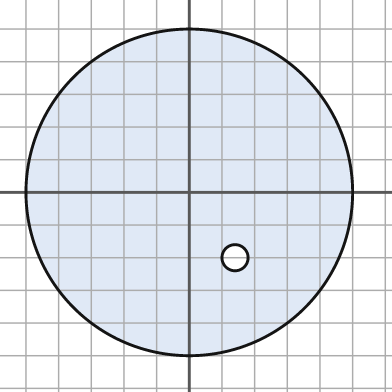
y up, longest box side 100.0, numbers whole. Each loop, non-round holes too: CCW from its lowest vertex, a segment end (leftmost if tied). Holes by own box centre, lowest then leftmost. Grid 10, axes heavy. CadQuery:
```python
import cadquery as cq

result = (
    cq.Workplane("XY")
    .moveTo(0.0, 0.0)
    .circle(50.0)
    .moveTo(14.0, -20.0)
    .circle(4.0)
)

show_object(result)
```